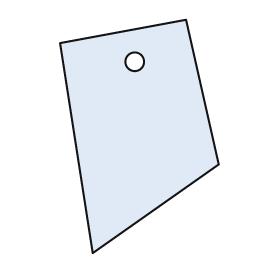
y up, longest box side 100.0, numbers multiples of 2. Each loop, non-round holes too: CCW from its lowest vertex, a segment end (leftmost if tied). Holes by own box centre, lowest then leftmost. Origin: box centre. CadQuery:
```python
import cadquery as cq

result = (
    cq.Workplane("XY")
    .moveTo(-20.0, -50.0)
    .lineTo(34.0, -12.0)
    .lineTo(20.0, 50.0)
    .lineTo(-34.0, 40.0)
    .close()
    .moveTo(-2.0, 32.0)
    .circle(4.0)
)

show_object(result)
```